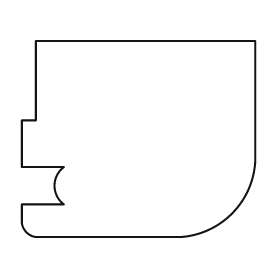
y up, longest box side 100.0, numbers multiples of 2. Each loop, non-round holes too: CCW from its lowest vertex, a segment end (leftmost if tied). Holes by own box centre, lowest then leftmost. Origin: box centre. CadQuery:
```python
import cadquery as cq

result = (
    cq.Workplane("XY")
    .moveTo(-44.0, -42.0)
    .lineTo(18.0, -42.0)
    .threePointArc((40.0, -32.0), (50.0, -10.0))
    .lineTo(50.0, 42.0)
    .lineTo(-44.0, 42.0)
    .lineTo(-44.0, 8.0)
    .lineTo(-50.0, 8.0)
    .lineTo(-50.0, -12.0)
    .lineTo(-32.0, -12.0)
    .threePointArc((-36.0, -20.0), (-32.0, -28.0))
    .lineTo(-50.0, -28.0)
    .lineTo(-50.0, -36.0)
    .threePointArc((-48.0, -40.0), (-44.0, -42.0))
    .close()
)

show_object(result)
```